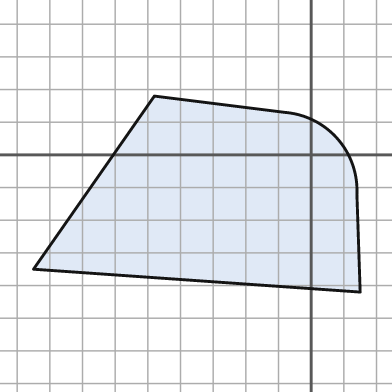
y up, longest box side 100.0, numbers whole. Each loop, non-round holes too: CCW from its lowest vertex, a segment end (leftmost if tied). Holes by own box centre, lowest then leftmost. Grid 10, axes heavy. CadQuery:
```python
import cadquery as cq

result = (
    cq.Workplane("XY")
    .moveTo(15.0, -42.0)
    .lineTo(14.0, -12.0)
    .threePointArc((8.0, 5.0), (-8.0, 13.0))
    .lineTo(-48.0, 18.0)
    .lineTo(-85.0, -35.0)
    .close()
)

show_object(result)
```